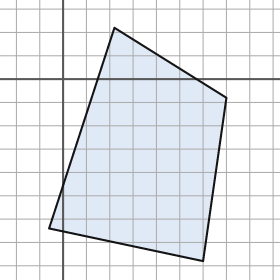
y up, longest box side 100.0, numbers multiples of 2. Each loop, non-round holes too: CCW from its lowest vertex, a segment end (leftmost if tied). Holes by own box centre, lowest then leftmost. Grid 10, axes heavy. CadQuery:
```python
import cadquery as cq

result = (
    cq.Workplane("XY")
    .moveTo(60.0, -78.0)
    .lineTo(70.0, -8.0)
    .lineTo(22.0, 22.0)
    .lineTo(-6.0, -64.0)
    .close()
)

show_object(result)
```